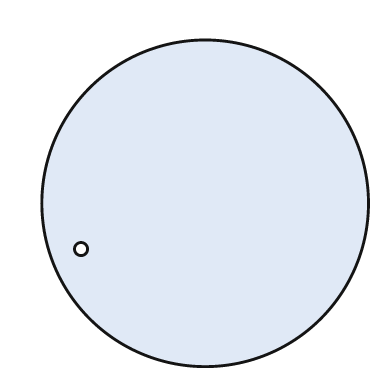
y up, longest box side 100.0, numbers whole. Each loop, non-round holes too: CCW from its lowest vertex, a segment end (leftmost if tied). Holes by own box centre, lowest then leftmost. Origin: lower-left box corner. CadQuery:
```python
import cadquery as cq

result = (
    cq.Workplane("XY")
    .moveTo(50.0, 50.0)
    .circle(50.0)
    .moveTo(12.0, 36.0)
    .circle(2.0)
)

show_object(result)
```